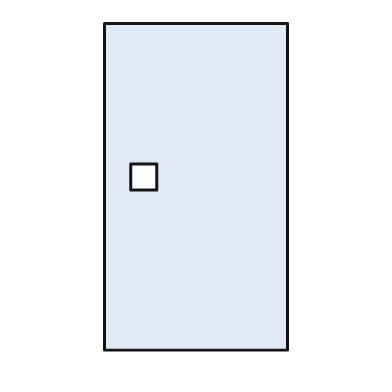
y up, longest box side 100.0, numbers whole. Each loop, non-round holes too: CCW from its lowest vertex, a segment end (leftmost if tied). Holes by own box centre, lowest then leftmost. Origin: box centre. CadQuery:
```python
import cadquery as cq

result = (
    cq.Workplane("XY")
    .moveTo(-28.0, -50.0)
    .lineTo(28.0, -50.0)
    .lineTo(28.0, 50.0)
    .lineTo(-28.0, 50.0)
    .close()
    .moveTo(-20.0, -1.0)
    .lineTo(-12.0, -1.0)
    .lineTo(-12.0, 7.0)
    .lineTo(-20.0, 7.0)
    .close()
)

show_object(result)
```